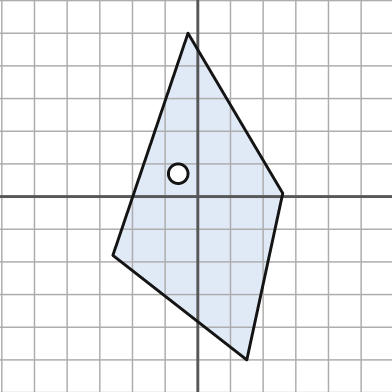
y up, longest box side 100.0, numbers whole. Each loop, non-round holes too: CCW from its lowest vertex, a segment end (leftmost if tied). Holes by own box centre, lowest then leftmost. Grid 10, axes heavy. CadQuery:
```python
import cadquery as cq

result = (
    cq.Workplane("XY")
    .moveTo(15.0, -50.0)
    .lineTo(26.0, 1.0)
    .lineTo(-3.0, 50.0)
    .lineTo(-26.0, -18.0)
    .close()
    .moveTo(-6.0, 7.0)
    .circle(3.0)
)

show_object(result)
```